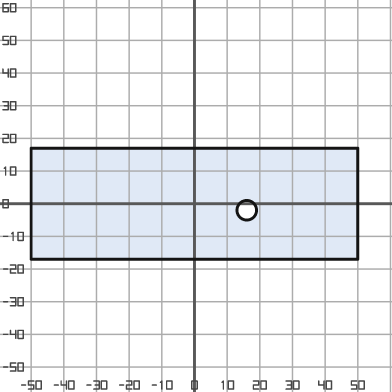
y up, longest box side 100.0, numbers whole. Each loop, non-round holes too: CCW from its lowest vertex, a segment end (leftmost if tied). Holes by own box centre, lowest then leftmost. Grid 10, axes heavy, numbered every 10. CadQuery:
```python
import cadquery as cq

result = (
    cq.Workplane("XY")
    .moveTo(-50.0, -17.0)
    .lineTo(50.0, -17.0)
    .lineTo(50.0, 17.0)
    .lineTo(-50.0, 17.0)
    .close()
    .moveTo(16.0, -2.0)
    .circle(3.0)
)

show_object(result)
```